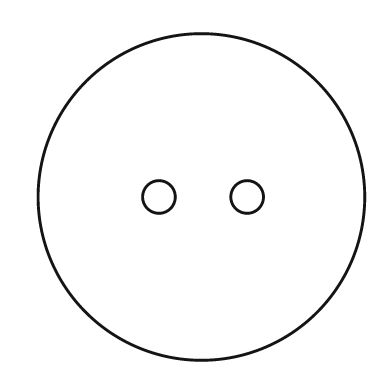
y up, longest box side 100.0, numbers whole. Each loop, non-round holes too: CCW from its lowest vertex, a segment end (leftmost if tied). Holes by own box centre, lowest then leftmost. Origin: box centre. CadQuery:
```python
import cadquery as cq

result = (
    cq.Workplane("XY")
    .moveTo(0.0, 0.0)
    .circle(50.0)
    .moveTo(-13.0, 0.0)
    .circle(5.0)
    .moveTo(14.0, 0.0)
    .circle(5.0)
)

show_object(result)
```